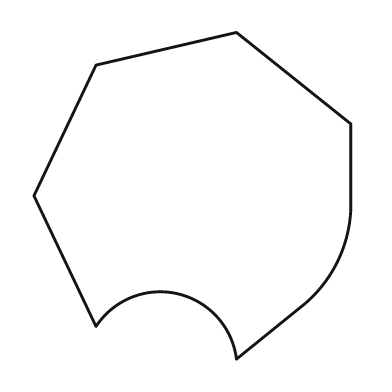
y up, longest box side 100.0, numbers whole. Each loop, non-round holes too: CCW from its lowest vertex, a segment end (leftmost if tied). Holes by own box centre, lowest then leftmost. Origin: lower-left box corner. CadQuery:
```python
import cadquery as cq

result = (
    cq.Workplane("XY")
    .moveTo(62.0, 0.0)
    .lineTo(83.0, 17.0)
    .threePointArc((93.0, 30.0), (97.0, 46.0))
    .lineTo(97.0, 72.0)
    .lineTo(62.0, 100.0)
    .lineTo(19.0, 90.0)
    .lineTo(0.0, 50.0)
    .lineTo(19.0, 10.0)
    .threePointArc((44.0, 20.0), (62.0, 0.0))
    .close()
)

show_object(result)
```